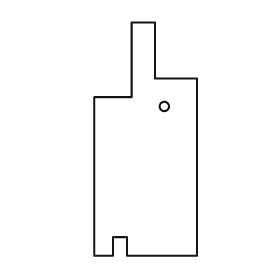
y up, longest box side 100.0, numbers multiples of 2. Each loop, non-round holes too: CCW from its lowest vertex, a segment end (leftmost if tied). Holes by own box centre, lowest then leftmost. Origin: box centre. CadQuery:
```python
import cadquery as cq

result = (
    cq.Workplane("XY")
    .moveTo(-22.0, -50.0)
    .lineTo(-14.0, -50.0)
    .lineTo(-14.0, -42.0)
    .lineTo(-8.0, -42.0)
    .lineTo(-8.0, -50.0)
    .lineTo(22.0, -50.0)
    .lineTo(22.0, 26.0)
    .lineTo(4.0, 26.0)
    .lineTo(4.0, 50.0)
    .lineTo(-6.0, 50.0)
    .lineTo(-6.0, 18.0)
    .lineTo(-22.0, 18.0)
    .close()
    .moveTo(8.0, 14.0)
    .circle(2.0)
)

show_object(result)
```